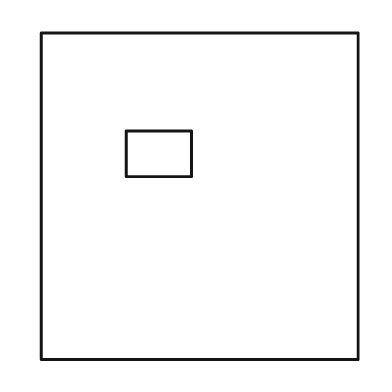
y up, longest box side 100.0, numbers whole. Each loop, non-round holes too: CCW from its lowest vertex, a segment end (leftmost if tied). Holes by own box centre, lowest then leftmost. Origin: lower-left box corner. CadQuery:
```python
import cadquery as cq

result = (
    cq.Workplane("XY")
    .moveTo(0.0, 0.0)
    .lineTo(97.0, 0.0)
    .lineTo(97.0, 100.0)
    .lineTo(0.0, 100.0)
    .close()
    .moveTo(26.0, 56.0)
    .lineTo(46.0, 56.0)
    .lineTo(46.0, 70.0)
    .lineTo(26.0, 70.0)
    .close()
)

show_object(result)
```